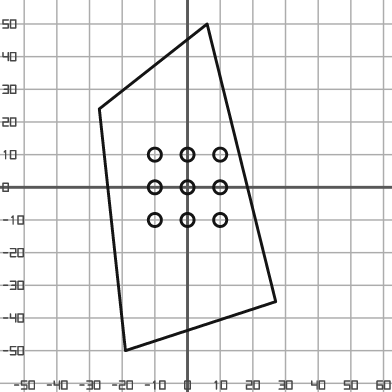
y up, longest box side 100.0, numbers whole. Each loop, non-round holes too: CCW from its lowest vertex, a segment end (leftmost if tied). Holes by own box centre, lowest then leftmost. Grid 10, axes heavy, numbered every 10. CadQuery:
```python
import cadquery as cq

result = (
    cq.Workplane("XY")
    .moveTo(-19.0, -50.0)
    .lineTo(27.0, -35.0)
    .lineTo(6.0, 50.0)
    .lineTo(-27.0, 24.0)
    .close()
    .moveTo(-10.0, -10.0)
    .circle(2.0)
    .moveTo(0.0, -10.0)
    .circle(2.0)
    .moveTo(10.0, -10.0)
    .circle(2.0)
    .moveTo(-10.0, 0.0)
    .circle(2.0)
    .moveTo(0.0, 0.0)
    .circle(2.0)
    .moveTo(10.0, 0.0)
    .circle(2.0)
    .moveTo(-10.0, 10.0)
    .circle(2.0)
    .moveTo(0.0, 10.0)
    .circle(2.0)
    .moveTo(10.0, 10.0)
    .circle(2.0)
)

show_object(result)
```